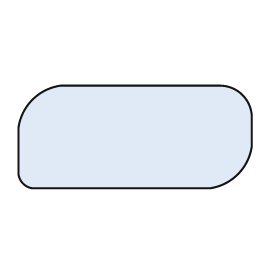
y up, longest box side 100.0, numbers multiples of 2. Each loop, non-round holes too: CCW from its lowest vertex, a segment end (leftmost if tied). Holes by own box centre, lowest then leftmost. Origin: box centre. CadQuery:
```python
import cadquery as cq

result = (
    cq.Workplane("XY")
    .moveTo(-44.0, -22.0)
    .lineTo(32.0, -22.0)
    .threePointArc((44.0, -16.0), (50.0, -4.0))
    .lineTo(50.0, 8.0)
    .threePointArc((46.0, 18.0), (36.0, 22.0))
    .lineTo(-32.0, 22.0)
    .threePointArc((-44.0, 16.0), (-50.0, 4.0))
    .lineTo(-50.0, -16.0)
    .threePointArc((-48.0, -20.0), (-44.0, -22.0))
    .close()
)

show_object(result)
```